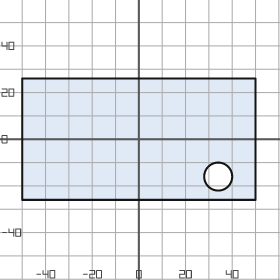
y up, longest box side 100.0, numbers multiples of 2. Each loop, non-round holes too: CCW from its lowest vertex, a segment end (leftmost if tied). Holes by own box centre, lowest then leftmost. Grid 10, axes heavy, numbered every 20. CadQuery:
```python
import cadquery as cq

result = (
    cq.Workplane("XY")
    .moveTo(-50.0, -26.0)
    .lineTo(50.0, -26.0)
    .lineTo(50.0, 26.0)
    .lineTo(-50.0, 26.0)
    .close()
    .moveTo(34.0, -16.0)
    .circle(6.0)
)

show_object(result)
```